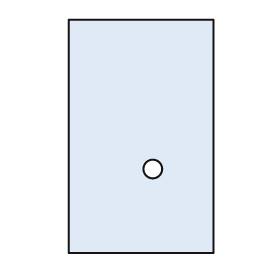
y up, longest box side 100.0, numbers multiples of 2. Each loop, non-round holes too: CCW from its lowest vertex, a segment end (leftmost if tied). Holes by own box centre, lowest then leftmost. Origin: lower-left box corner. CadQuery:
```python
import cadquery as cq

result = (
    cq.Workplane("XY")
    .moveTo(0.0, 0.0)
    .lineTo(62.0, 0.0)
    .lineTo(62.0, 100.0)
    .lineTo(0.0, 100.0)
    .close()
    .moveTo(36.0, 36.0)
    .circle(4.0)
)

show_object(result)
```